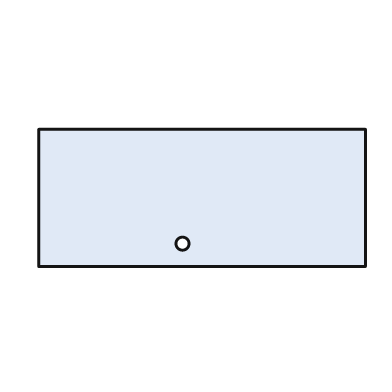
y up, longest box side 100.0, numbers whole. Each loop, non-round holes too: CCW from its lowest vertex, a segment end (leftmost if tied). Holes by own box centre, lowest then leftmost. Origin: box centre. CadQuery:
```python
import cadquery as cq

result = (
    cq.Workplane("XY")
    .moveTo(-50.0, -21.0)
    .lineTo(50.0, -21.0)
    .lineTo(50.0, 21.0)
    .lineTo(-50.0, 21.0)
    .close()
    .moveTo(-6.0, -14.0)
    .circle(2.0)
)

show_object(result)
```